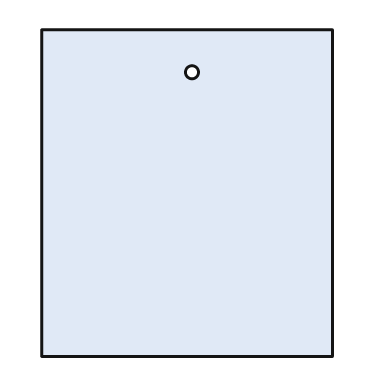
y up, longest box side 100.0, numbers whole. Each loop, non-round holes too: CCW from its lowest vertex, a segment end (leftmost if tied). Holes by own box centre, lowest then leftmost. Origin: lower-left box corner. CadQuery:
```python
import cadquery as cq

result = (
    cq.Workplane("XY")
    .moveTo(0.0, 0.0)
    .lineTo(89.0, 0.0)
    .lineTo(89.0, 100.0)
    .lineTo(0.0, 100.0)
    .close()
    .moveTo(46.0, 87.0)
    .circle(2.0)
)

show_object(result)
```